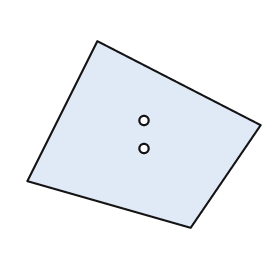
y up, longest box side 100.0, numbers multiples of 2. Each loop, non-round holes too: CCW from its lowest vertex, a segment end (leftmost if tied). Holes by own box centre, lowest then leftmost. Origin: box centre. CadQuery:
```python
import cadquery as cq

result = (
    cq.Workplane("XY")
    .moveTo(20.0, -40.0)
    .lineTo(50.0, 4.0)
    .lineTo(-20.0, 40.0)
    .lineTo(-50.0, -20.0)
    .close()
    .moveTo(0.0, -6.0)
    .circle(2.0)
    .moveTo(0.0, 6.0)
    .circle(2.0)
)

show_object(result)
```